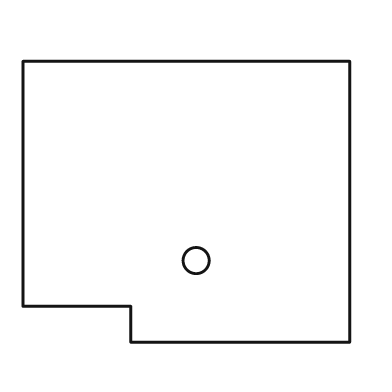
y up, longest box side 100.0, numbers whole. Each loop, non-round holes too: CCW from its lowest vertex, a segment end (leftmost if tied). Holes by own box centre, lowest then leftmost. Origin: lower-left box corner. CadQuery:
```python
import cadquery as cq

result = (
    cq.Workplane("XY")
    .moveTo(33.0, 0.0)
    .lineTo(100.0, 0.0)
    .lineTo(100.0, 86.0)
    .lineTo(0.0, 86.0)
    .lineTo(0.0, 11.0)
    .lineTo(33.0, 11.0)
    .close()
    .moveTo(53.0, 25.0)
    .circle(4.0)
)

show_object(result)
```